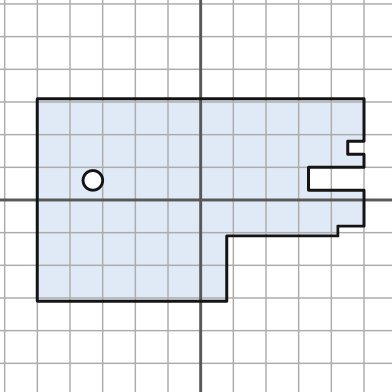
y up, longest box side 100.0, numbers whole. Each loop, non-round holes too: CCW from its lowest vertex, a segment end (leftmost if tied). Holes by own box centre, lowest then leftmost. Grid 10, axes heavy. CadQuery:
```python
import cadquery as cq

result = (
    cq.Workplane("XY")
    .moveTo(-50.0, -31.0)
    .lineTo(8.0, -31.0)
    .lineTo(8.0, -11.0)
    .lineTo(42.0, -11.0)
    .lineTo(42.0, -8.0)
    .lineTo(50.0, -8.0)
    .lineTo(50.0, 3.0)
    .lineTo(33.0, 3.0)
    .lineTo(33.0, 10.0)
    .lineTo(50.0, 10.0)
    .lineTo(50.0, 14.0)
    .lineTo(45.0, 14.0)
    .lineTo(45.0, 18.0)
    .lineTo(50.0, 18.0)
    .lineTo(50.0, 31.0)
    .lineTo(-50.0, 31.0)
    .close()
    .moveTo(-33.0, 6.0)
    .circle(3.0)
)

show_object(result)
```